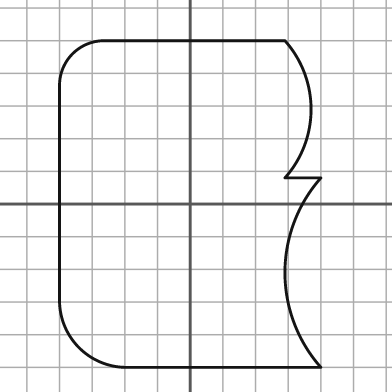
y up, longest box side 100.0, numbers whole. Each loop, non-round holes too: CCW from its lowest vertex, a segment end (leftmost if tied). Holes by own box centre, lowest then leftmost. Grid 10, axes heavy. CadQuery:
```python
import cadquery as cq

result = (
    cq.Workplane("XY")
    .moveTo(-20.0, -50.0)
    .lineTo(40.0, -50.0)
    .threePointArc((29.0, -21.0), (40.0, 8.0))
    .lineTo(29.0, 8.0)
    .threePointArc((37.0, 29.0), (29.0, 50.0))
    .lineTo(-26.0, 50.0)
    .threePointArc((-36.0, 46.0), (-40.0, 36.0))
    .lineTo(-40.0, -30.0)
    .threePointArc((-34.0, -44.0), (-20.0, -50.0))
    .close()
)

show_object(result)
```